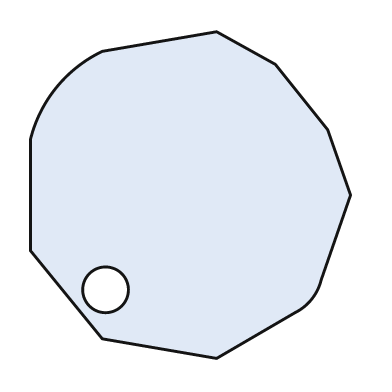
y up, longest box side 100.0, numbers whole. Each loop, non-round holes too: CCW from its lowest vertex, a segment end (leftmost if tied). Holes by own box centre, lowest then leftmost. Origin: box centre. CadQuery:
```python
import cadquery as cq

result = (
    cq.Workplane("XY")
    .moveTo(8.0, -50.0)
    .lineTo(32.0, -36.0)
    .threePointArc((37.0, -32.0), (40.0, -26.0))
    .lineTo(49.0, 0.0)
    .lineTo(42.0, 20.0)
    .lineTo(26.0, 40.0)
    .lineTo(8.0, 50.0)
    .lineTo(-27.0, 44.0)
    .threePointArc((-41.0, 33.0), (-49.0, 17.0))
    .lineTo(-49.0, -17.0)
    .lineTo(-27.0, -44.0)
    .close()
    .moveTo(-26.0, -29.0)
    .circle(7.0)
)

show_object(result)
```